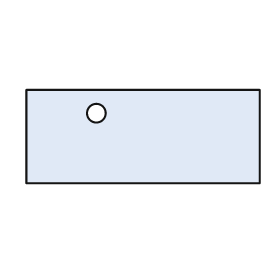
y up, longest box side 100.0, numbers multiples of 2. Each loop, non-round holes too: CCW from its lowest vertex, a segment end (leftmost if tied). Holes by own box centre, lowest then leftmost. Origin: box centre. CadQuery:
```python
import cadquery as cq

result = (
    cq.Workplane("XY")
    .moveTo(-50.0, -20.0)
    .lineTo(50.0, -20.0)
    .lineTo(50.0, 20.0)
    .lineTo(-50.0, 20.0)
    .close()
    .moveTo(-20.0, 10.0)
    .circle(4.0)
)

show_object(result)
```